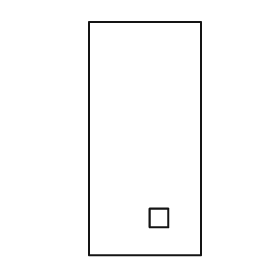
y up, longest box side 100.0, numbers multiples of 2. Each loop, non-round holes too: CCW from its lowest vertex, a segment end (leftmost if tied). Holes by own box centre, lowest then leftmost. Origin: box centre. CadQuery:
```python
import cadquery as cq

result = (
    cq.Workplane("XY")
    .moveTo(-24.0, -50.0)
    .lineTo(24.0, -50.0)
    .lineTo(24.0, 50.0)
    .lineTo(-24.0, 50.0)
    .close()
    .moveTo(2.0, -38.0)
    .lineTo(10.0, -38.0)
    .lineTo(10.0, -30.0)
    .lineTo(2.0, -30.0)
    .close()
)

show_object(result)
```